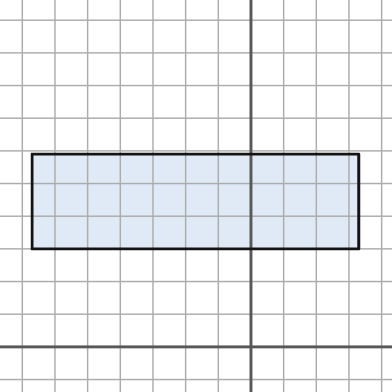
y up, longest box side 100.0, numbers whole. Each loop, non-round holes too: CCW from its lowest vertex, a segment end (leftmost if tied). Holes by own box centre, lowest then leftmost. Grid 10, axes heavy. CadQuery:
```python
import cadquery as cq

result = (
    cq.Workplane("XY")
    .moveTo(-67.0, 30.0)
    .lineTo(33.0, 30.0)
    .lineTo(33.0, 59.0)
    .lineTo(-67.0, 59.0)
    .close()
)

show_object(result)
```